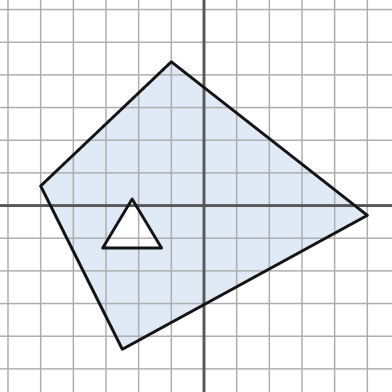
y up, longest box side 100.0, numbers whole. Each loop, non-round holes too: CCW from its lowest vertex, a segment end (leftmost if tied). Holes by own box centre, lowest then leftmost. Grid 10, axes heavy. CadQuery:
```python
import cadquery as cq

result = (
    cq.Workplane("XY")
    .moveTo(-25.0, -44.0)
    .lineTo(50.0, -3.0)
    .lineTo(-10.0, 44.0)
    .lineTo(-50.0, 6.0)
    .close()
    .moveTo(-31.0, -13.0)
    .lineTo(-13.0, -13.0)
    .lineTo(-22.0, 2.0)
    .close()
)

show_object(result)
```